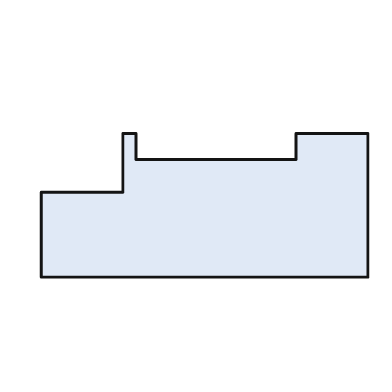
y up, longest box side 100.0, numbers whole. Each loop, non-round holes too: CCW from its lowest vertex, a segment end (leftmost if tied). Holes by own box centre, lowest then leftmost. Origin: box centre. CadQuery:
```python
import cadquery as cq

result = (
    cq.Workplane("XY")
    .moveTo(-50.0, -22.0)
    .lineTo(50.0, -22.0)
    .lineTo(50.0, 22.0)
    .lineTo(28.0, 22.0)
    .lineTo(28.0, 14.0)
    .lineTo(-21.0, 14.0)
    .lineTo(-21.0, 22.0)
    .lineTo(-25.0, 22.0)
    .lineTo(-25.0, 4.0)
    .lineTo(-50.0, 4.0)
    .close()
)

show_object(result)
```